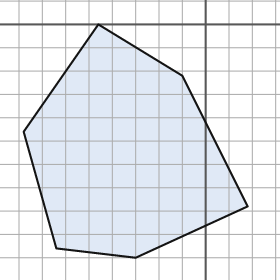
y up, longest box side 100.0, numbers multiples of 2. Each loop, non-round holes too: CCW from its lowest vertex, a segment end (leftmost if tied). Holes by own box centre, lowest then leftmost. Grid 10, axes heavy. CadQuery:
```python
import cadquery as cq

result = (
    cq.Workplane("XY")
    .moveTo(-30.0, -100.0)
    .lineTo(18.0, -78.0)
    .lineTo(-10.0, -22.0)
    .lineTo(-46.0, 0.0)
    .lineTo(-78.0, -46.0)
    .lineTo(-64.0, -96.0)
    .close()
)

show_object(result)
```